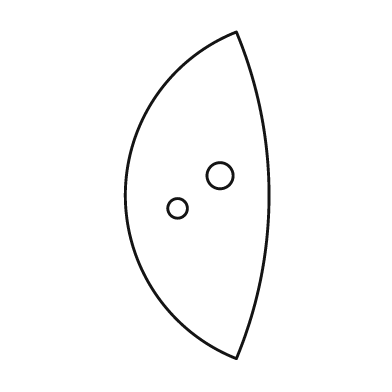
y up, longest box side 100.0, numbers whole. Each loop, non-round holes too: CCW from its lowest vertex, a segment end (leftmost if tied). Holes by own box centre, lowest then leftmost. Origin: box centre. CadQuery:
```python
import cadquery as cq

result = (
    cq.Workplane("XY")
    .moveTo(12.0, -50.0)
    .threePointArc((22.0, 0.0), (12.0, 50.0))
    .threePointArc((-22.0, 0.0), (12.0, -50.0))
    .close()
    .moveTo(-6.0, -4.0)
    .circle(3.0)
    .moveTo(7.0, 6.0)
    .circle(4.0)
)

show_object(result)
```